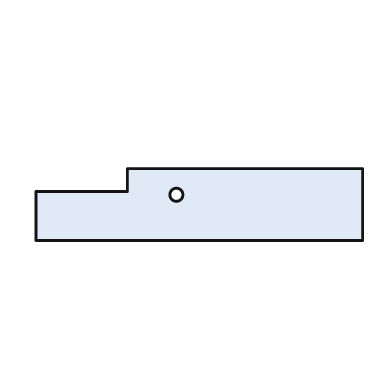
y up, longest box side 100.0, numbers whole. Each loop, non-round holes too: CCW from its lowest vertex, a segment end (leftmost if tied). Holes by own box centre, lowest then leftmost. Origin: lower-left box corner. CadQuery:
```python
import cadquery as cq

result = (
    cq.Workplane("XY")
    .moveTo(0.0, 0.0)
    .lineTo(100.0, 0.0)
    .lineTo(100.0, 22.0)
    .lineTo(28.0, 22.0)
    .lineTo(28.0, 15.0)
    .lineTo(0.0, 15.0)
    .close()
    .moveTo(43.0, 14.0)
    .circle(2.0)
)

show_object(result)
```